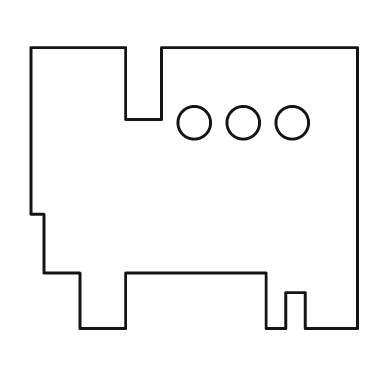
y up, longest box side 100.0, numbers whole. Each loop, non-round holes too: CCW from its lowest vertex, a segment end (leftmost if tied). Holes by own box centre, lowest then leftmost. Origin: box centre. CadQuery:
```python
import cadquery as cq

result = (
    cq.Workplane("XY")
    .moveTo(-35.0, -43.0)
    .lineTo(-21.0, -43.0)
    .lineTo(-21.0, -26.0)
    .lineTo(22.0, -26.0)
    .lineTo(22.0, -43.0)
    .lineTo(28.0, -43.0)
    .lineTo(28.0, -32.0)
    .lineTo(34.0, -32.0)
    .lineTo(34.0, -43.0)
    .lineTo(50.0, -43.0)
    .lineTo(50.0, 43.0)
    .lineTo(-10.0, 43.0)
    .lineTo(-10.0, 21.0)
    .lineTo(-21.0, 21.0)
    .lineTo(-21.0, 43.0)
    .lineTo(-50.0, 43.0)
    .lineTo(-50.0, -8.0)
    .lineTo(-46.0, -8.0)
    .lineTo(-46.0, -26.0)
    .lineTo(-35.0, -26.0)
    .close()
    .moveTo(0.0, 20.0)
    .circle(5.0)
    .moveTo(15.0, 20.0)
    .circle(5.0)
    .moveTo(30.0, 20.0)
    .circle(5.0)
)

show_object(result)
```